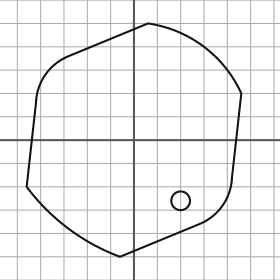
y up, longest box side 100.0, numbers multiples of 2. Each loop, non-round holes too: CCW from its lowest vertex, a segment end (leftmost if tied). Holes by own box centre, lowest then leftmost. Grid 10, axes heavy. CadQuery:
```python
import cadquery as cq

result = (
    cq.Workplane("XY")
    .moveTo(-6.0, -50.0)
    .lineTo(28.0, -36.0)
    .threePointArc((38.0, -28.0), (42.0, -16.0))
    .lineTo(46.0, 20.0)
    .threePointArc((30.0, 40.0), (6.0, 50.0))
    .lineTo(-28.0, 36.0)
    .threePointArc((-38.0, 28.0), (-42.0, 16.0))
    .lineTo(-46.0, -20.0)
    .threePointArc((-28.0, -38.0), (-6.0, -50.0))
    .close()
    .moveTo(20.0, -26.0)
    .circle(4.0)
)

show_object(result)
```